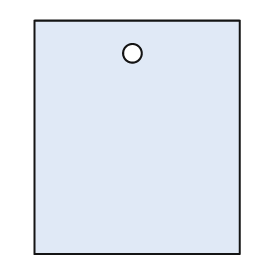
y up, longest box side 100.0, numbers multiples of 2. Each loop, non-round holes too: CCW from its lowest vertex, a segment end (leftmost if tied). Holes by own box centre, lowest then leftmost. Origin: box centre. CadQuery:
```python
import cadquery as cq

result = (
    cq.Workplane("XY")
    .moveTo(-44.0, -50.0)
    .lineTo(44.0, -50.0)
    .lineTo(44.0, 50.0)
    .lineTo(-44.0, 50.0)
    .close()
    .moveTo(-2.0, 36.0)
    .circle(4.0)
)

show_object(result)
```